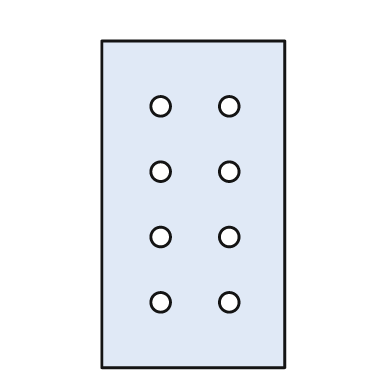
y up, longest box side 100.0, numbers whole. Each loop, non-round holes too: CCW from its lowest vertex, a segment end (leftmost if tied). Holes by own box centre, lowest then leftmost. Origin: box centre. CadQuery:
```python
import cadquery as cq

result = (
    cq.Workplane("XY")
    .moveTo(-28.0, -50.0)
    .lineTo(28.0, -50.0)
    .lineTo(28.0, 50.0)
    .lineTo(-28.0, 50.0)
    .close()
    .moveTo(-10.0, -30.0)
    .circle(3.0)
    .moveTo(11.0, -30.0)
    .circle(3.0)
    .moveTo(-10.0, -10.0)
    .circle(3.0)
    .moveTo(11.0, -10.0)
    .circle(3.0)
    .moveTo(-10.0, 10.0)
    .circle(3.0)
    .moveTo(11.0, 10.0)
    .circle(3.0)
    .moveTo(-10.0, 30.0)
    .circle(3.0)
    .moveTo(11.0, 30.0)
    .circle(3.0)
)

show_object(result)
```